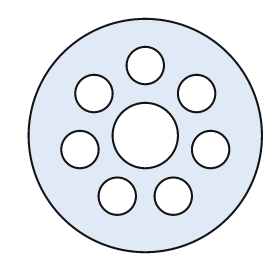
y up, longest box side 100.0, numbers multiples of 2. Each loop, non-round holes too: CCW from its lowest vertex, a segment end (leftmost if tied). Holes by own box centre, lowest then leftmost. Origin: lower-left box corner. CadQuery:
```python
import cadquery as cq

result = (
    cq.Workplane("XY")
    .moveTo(50.0, 50.0)
    .circle(50.0)
    .moveTo(38.0, 24.0)
    .circle(8.0)
    .moveTo(62.0, 24.0)
    .circle(8.0)
    .moveTo(22.0, 44.0)
    .circle(8.0)
    .moveTo(78.0, 44.0)
    .circle(8.0)
    .moveTo(50.0, 50.0)
    .circle(14.0)
    .moveTo(28.0, 68.0)
    .circle(8.0)
    .moveTo(72.0, 68.0)
    .circle(8.0)
    .moveTo(50.0, 80.0)
    .circle(8.0)
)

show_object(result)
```